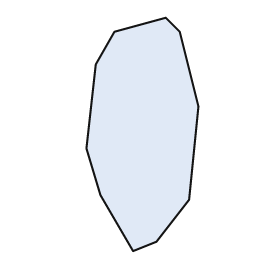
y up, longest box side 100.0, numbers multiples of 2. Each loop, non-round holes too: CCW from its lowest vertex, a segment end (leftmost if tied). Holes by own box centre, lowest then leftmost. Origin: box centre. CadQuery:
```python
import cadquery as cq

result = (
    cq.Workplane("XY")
    .moveTo(-4.0, -50.0)
    .lineTo(6.0, -46.0)
    .lineTo(20.0, -28.0)
    .lineTo(24.0, 12.0)
    .lineTo(16.0, 44.0)
    .lineTo(10.0, 50.0)
    .lineTo(-12.0, 44.0)
    .lineTo(-20.0, 30.0)
    .lineTo(-24.0, -6.0)
    .lineTo(-18.0, -26.0)
    .close()
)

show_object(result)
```